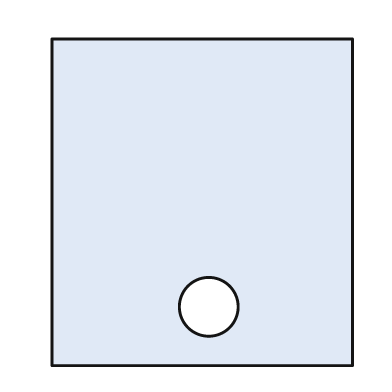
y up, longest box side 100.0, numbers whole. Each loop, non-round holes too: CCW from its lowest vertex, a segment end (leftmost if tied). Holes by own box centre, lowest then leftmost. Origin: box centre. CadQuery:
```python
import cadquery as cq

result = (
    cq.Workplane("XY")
    .moveTo(-46.0, -50.0)
    .lineTo(46.0, -50.0)
    .lineTo(46.0, 50.0)
    .lineTo(-46.0, 50.0)
    .close()
    .moveTo(2.0, -32.0)
    .circle(9.0)
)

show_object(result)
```